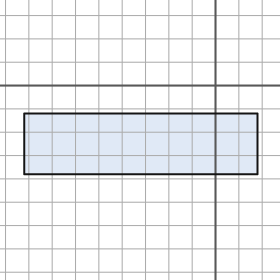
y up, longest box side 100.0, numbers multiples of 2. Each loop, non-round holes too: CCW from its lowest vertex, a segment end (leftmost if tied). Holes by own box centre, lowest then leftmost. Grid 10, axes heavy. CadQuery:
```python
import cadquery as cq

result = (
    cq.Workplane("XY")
    .moveTo(-82.0, -38.0)
    .lineTo(18.0, -38.0)
    .lineTo(18.0, -12.0)
    .lineTo(-82.0, -12.0)
    .close()
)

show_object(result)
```